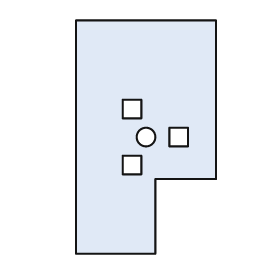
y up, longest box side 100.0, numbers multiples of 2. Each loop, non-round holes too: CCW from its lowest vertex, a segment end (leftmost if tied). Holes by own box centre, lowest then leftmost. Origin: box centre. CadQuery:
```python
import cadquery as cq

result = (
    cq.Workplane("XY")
    .moveTo(-30.0, -50.0)
    .lineTo(4.0, -50.0)
    .lineTo(4.0, -18.0)
    .lineTo(30.0, -18.0)
    .lineTo(30.0, 50.0)
    .lineTo(-30.0, 50.0)
    .close()
    .moveTo(-10.0, -16.0)
    .lineTo(-2.0, -16.0)
    .lineTo(-2.0, -8.0)
    .lineTo(-10.0, -8.0)
    .close()
    .moveTo(0.0, 0.0)
    .circle(4.0)
    .moveTo(10.0, -4.0)
    .lineTo(18.0, -4.0)
    .lineTo(18.0, 4.0)
    .lineTo(10.0, 4.0)
    .close()
    .moveTo(-10.0, 8.0)
    .lineTo(-2.0, 8.0)
    .lineTo(-2.0, 16.0)
    .lineTo(-10.0, 16.0)
    .close()
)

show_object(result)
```